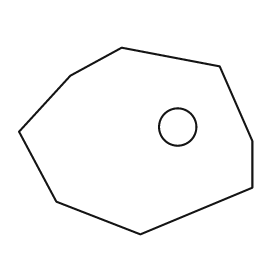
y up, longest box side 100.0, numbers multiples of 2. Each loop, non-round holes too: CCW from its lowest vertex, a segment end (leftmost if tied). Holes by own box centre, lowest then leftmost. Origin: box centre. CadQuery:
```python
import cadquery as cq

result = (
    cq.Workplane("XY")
    .moveTo(2.0, -40.0)
    .lineTo(50.0, -20.0)
    .lineTo(50.0, 0.0)
    .lineTo(36.0, 32.0)
    .lineTo(-6.0, 40.0)
    .lineTo(-28.0, 28.0)
    .lineTo(-50.0, 4.0)
    .lineTo(-34.0, -26.0)
    .close()
    .moveTo(18.0, 6.0)
    .circle(8.0)
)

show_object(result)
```